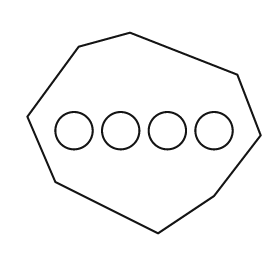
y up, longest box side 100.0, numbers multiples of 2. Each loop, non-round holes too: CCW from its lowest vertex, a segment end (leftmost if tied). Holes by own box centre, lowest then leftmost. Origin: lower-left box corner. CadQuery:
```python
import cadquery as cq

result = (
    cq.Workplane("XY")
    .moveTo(56.0, 0.0)
    .lineTo(80.0, 16.0)
    .lineTo(100.0, 42.0)
    .lineTo(90.0, 68.0)
    .lineTo(44.0, 86.0)
    .lineTo(22.0, 80.0)
    .lineTo(0.0, 50.0)
    .lineTo(12.0, 22.0)
    .close()
    .moveTo(20.0, 44.0)
    .circle(8.0)
    .moveTo(40.0, 44.0)
    .circle(8.0)
    .moveTo(60.0, 44.0)
    .circle(8.0)
    .moveTo(80.0, 44.0)
    .circle(8.0)
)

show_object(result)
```